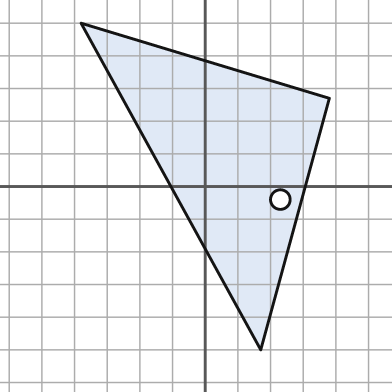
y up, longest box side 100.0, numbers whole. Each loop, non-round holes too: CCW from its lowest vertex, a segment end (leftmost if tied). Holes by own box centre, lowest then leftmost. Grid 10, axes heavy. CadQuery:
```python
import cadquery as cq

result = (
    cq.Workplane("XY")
    .moveTo(17.0, -50.0)
    .lineTo(38.0, 27.0)
    .lineTo(-38.0, 50.0)
    .close()
    .moveTo(23.0, -4.0)
    .circle(3.0)
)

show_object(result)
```